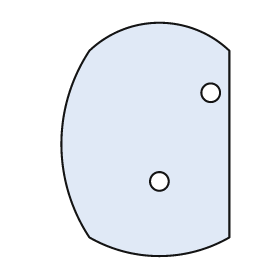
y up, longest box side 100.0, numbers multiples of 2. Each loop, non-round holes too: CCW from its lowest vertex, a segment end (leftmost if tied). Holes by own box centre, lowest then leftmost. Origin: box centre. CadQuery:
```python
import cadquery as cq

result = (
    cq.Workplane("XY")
    .moveTo(-24.0, -42.0)
    .threePointArc((6.0, -50.0), (36.0, -42.0))
    .lineTo(36.0, 38.0)
    .threePointArc((6.0, 50.0), (-24.0, 38.0))
    .threePointArc((-36.0, -2.0), (-24.0, -42.0))
    .close()
    .moveTo(6.0, -18.0)
    .circle(4.0)
    .moveTo(28.0, 20.0)
    .circle(4.0)
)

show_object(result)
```